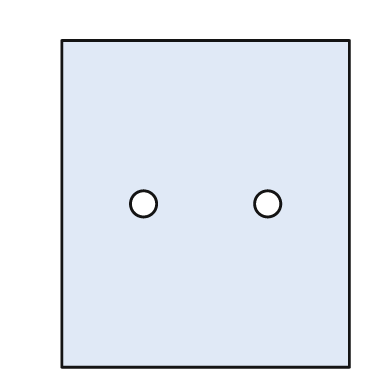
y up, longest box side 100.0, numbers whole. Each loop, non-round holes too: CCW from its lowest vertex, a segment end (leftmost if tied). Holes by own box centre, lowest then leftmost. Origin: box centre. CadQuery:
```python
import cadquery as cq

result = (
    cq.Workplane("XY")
    .moveTo(-44.0, -50.0)
    .lineTo(44.0, -50.0)
    .lineTo(44.0, 50.0)
    .lineTo(-44.0, 50.0)
    .close()
    .moveTo(-19.0, 0.0)
    .circle(4.0)
    .moveTo(19.0, 0.0)
    .circle(4.0)
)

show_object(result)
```